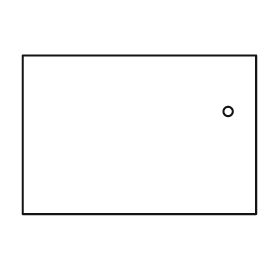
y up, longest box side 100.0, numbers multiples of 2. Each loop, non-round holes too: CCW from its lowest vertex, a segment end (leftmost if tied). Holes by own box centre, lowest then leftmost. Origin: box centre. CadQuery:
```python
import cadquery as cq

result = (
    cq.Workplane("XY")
    .moveTo(-50.0, -34.0)
    .lineTo(50.0, -34.0)
    .lineTo(50.0, 34.0)
    .lineTo(-50.0, 34.0)
    .close()
    .moveTo(38.0, 10.0)
    .circle(2.0)
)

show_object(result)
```